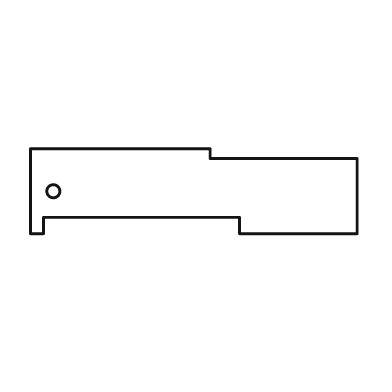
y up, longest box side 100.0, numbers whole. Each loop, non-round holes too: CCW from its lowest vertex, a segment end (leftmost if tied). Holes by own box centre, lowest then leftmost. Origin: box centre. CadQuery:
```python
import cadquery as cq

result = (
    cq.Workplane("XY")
    .moveTo(-50.0, -13.0)
    .lineTo(-46.0, -13.0)
    .lineTo(-46.0, -8.0)
    .lineTo(14.0, -8.0)
    .lineTo(14.0, -13.0)
    .lineTo(50.0, -13.0)
    .lineTo(50.0, 10.0)
    .lineTo(5.0, 10.0)
    .lineTo(5.0, 13.0)
    .lineTo(-50.0, 13.0)
    .close()
    .moveTo(-43.0, 0.0)
    .circle(2.0)
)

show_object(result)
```